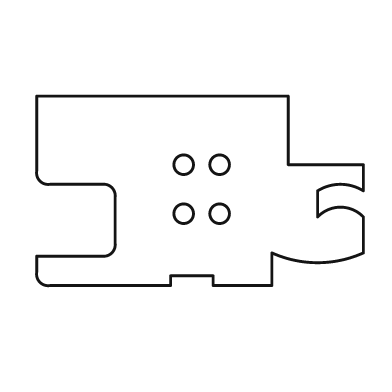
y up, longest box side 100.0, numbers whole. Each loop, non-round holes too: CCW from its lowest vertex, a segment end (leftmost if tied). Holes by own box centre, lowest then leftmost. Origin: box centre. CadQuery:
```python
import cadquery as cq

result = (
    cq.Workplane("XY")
    .moveTo(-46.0, -29.0)
    .lineTo(-9.0, -29.0)
    .lineTo(-9.0, -26.0)
    .lineTo(4.0, -26.0)
    .lineTo(4.0, -29.0)
    .lineTo(22.0, -29.0)
    .lineTo(22.0, -19.0)
    .threePointArc((36.0, -22.0), (50.0, -19.0))
    .lineTo(50.0, -8.0)
    .threePointArc((43.0, -5.0), (36.0, -8.0))
    .lineTo(36.0, 0.0)
    .threePointArc((43.0, 2.0), (50.0, 0.0))
    .lineTo(50.0, 8.0)
    .lineTo(27.0, 8.0)
    .lineTo(27.0, 29.0)
    .lineTo(-50.0, 29.0)
    .lineTo(-50.0, 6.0)
    .threePointArc((-49.0, 3.0), (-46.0, 2.0))
    .lineTo(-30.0, 2.0)
    .threePointArc((-27.0, 1.0), (-26.0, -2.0))
    .lineTo(-26.0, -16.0)
    .threePointArc((-27.0, -19.0), (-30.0, -20.0))
    .lineTo(-50.0, -20.0)
    .lineTo(-50.0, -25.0)
    .threePointArc((-49.0, -28.0), (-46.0, -29.0))
    .close()
    .moveTo(-5.0, -7.0)
    .circle(3.0)
    .moveTo(6.0, -7.0)
    .circle(3.0)
    .moveTo(-5.0, 8.0)
    .circle(3.0)
    .moveTo(6.0, 8.0)
    .circle(3.0)
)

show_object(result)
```